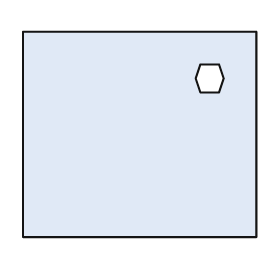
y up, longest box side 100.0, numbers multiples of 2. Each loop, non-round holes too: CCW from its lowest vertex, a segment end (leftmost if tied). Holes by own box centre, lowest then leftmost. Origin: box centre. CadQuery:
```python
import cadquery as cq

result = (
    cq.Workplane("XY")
    .moveTo(-50.0, -44.0)
    .lineTo(50.0, -44.0)
    .lineTo(50.0, 44.0)
    .lineTo(-50.0, 44.0)
    .close()
    .moveTo(26.0, 18.0)
    .lineTo(34.0, 18.0)
    .lineTo(36.0, 24.0)
    .lineTo(34.0, 30.0)
    .lineTo(26.0, 30.0)
    .lineTo(24.0, 24.0)
    .close()
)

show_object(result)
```